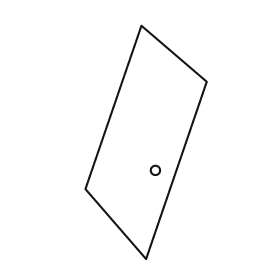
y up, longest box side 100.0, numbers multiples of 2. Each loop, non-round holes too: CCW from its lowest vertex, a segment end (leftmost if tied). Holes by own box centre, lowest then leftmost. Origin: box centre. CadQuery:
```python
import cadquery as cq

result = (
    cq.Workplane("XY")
    .moveTo(0.0, -50.0)
    .lineTo(26.0, 26.0)
    .lineTo(-2.0, 50.0)
    .lineTo(-26.0, -20.0)
    .close()
    .moveTo(4.0, -12.0)
    .circle(2.0)
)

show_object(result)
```